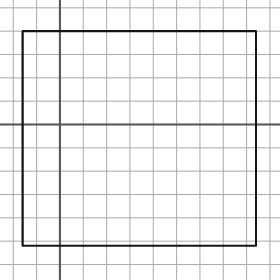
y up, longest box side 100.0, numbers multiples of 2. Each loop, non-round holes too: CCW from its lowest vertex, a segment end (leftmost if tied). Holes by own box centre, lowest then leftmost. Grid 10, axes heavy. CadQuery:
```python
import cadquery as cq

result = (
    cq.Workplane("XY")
    .moveTo(-16.0, -52.0)
    .lineTo(84.0, -52.0)
    .lineTo(84.0, 40.0)
    .lineTo(-16.0, 40.0)
    .close()
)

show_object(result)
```